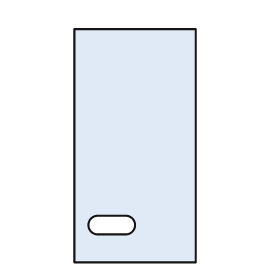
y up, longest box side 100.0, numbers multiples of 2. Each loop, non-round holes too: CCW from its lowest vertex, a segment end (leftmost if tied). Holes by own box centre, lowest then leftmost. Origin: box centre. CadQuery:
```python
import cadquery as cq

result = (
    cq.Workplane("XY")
    .moveTo(-26.0, -50.0)
    .lineTo(26.0, -50.0)
    .lineTo(26.0, 50.0)
    .lineTo(-26.0, 50.0)
    .close()
    .moveTo(-16.0, -38.0)
    .lineTo(-4.0, -38.0)
    .threePointArc((0.0, -34.0), (-4.0, -30.0))
    .lineTo(-16.0, -30.0)
    .threePointArc((-20.0, -34.0), (-16.0, -38.0))
    .close()
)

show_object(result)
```